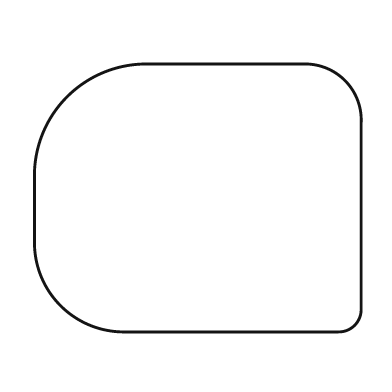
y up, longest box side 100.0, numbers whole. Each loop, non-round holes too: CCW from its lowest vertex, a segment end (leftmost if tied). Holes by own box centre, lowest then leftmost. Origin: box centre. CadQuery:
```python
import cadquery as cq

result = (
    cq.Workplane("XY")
    .moveTo(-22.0, -41.0)
    .lineTo(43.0, -41.0)
    .threePointArc((48.0, -39.0), (50.0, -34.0))
    .lineTo(50.0, 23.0)
    .threePointArc((45.0, 36.0), (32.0, 41.0))
    .lineTo(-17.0, 41.0)
    .threePointArc((-40.0, 31.0), (-50.0, 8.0))
    .lineTo(-50.0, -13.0)
    .threePointArc((-42.0, -33.0), (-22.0, -41.0))
    .close()
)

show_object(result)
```